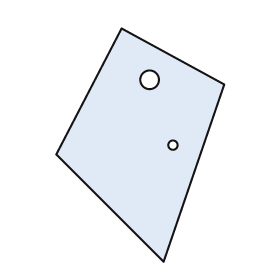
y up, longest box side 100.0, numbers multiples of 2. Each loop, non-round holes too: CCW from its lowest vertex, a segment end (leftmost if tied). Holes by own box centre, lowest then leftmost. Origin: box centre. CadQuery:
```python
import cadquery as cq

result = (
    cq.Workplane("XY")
    .moveTo(10.0, -50.0)
    .lineTo(36.0, 26.0)
    .lineTo(-8.0, 50.0)
    .lineTo(-36.0, -4.0)
    .close()
    .moveTo(14.0, 0.0)
    .circle(2.0)
    .moveTo(4.0, 28.0)
    .circle(4.0)
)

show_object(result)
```